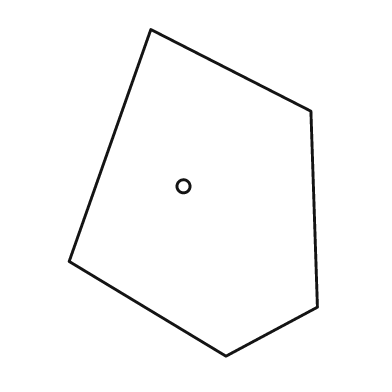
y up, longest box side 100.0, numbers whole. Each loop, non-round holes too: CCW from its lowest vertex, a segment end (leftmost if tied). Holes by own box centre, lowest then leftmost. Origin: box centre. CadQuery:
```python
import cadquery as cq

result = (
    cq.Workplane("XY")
    .moveTo(10.0, -50.0)
    .lineTo(38.0, -35.0)
    .lineTo(36.0, 25.0)
    .lineTo(-13.0, 50.0)
    .lineTo(-38.0, -21.0)
    .close()
    .moveTo(-3.0, 2.0)
    .circle(2.0)
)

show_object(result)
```